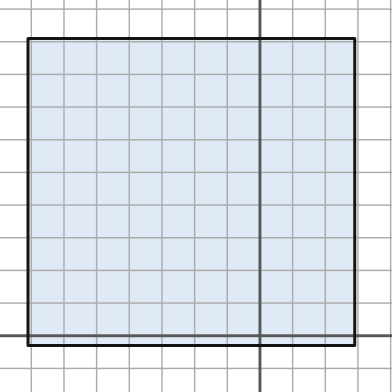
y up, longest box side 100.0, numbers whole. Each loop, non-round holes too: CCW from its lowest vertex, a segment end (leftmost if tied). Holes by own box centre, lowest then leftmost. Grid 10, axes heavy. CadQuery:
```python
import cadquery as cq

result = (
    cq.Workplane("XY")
    .moveTo(-71.0, -3.0)
    .lineTo(29.0, -3.0)
    .lineTo(29.0, 91.0)
    .lineTo(-71.0, 91.0)
    .close()
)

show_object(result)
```